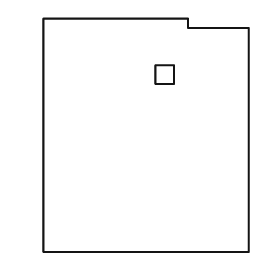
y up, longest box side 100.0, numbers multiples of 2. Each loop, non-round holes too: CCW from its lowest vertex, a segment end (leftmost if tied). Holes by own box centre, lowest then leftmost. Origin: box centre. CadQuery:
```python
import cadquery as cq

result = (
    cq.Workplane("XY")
    .moveTo(-44.0, -50.0)
    .lineTo(44.0, -50.0)
    .lineTo(44.0, 46.0)
    .lineTo(18.0, 46.0)
    .lineTo(18.0, 50.0)
    .lineTo(-44.0, 50.0)
    .close()
    .moveTo(4.0, 22.0)
    .lineTo(12.0, 22.0)
    .lineTo(12.0, 30.0)
    .lineTo(4.0, 30.0)
    .close()
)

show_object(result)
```